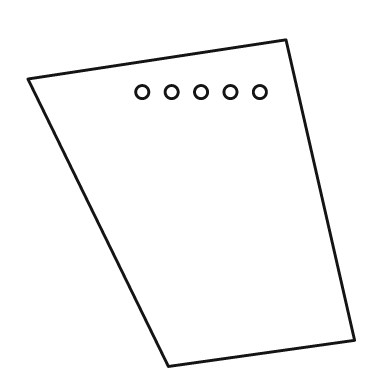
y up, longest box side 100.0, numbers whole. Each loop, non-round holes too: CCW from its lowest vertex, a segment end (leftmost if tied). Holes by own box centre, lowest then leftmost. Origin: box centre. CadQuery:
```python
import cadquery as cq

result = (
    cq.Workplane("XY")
    .moveTo(-7.0, -50.0)
    .lineTo(50.0, -42.0)
    .lineTo(29.0, 50.0)
    .lineTo(-50.0, 38.0)
    .close()
    .moveTo(-15.0, 34.0)
    .circle(2.0)
    .moveTo(-6.0, 34.0)
    .circle(2.0)
    .moveTo(3.0, 34.0)
    .circle(2.0)
    .moveTo(12.0, 34.0)
    .circle(2.0)
    .moveTo(21.0, 34.0)
    .circle(2.0)
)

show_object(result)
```